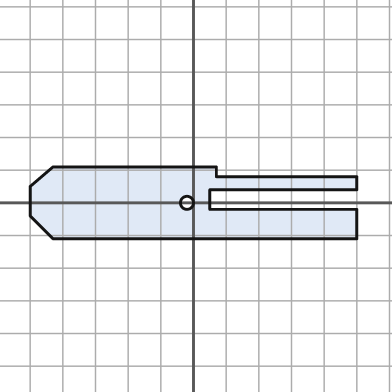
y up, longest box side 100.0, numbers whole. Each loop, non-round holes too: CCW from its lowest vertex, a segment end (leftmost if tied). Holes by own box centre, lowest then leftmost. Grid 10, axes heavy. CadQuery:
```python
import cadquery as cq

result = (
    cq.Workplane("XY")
    .moveTo(-43.0, -11.0)
    .lineTo(50.0, -11.0)
    .lineTo(50.0, -2.0)
    .lineTo(5.0, -2.0)
    .lineTo(5.0, 4.0)
    .lineTo(50.0, 4.0)
    .lineTo(50.0, 8.0)
    .lineTo(7.0, 8.0)
    .lineTo(7.0, 11.0)
    .lineTo(-43.0, 11.0)
    .lineTo(-50.0, 5.0)
    .lineTo(-50.0, -4.0)
    .close()
    .moveTo(-2.0, 0.0)
    .circle(2.0)
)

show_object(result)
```